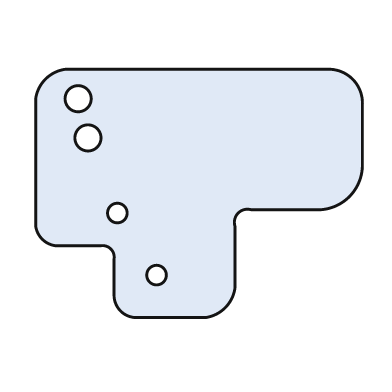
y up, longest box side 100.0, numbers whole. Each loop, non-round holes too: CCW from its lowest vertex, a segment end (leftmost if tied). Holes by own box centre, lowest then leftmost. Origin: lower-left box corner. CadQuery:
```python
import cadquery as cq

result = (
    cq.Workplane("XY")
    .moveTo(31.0, 0.0)
    .lineTo(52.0, 0.0)
    .threePointArc((58.0, 3.0), (61.0, 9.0))
    .lineTo(61.0, 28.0)
    .threePointArc((62.0, 32.0), (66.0, 33.0))
    .lineTo(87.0, 33.0)
    .threePointArc((96.0, 37.0), (100.0, 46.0))
    .lineTo(100.0, 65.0)
    .threePointArc((97.0, 73.0), (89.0, 76.0))
    .lineTo(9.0, 76.0)
    .threePointArc((3.0, 73.0), (0.0, 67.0))
    .lineTo(0.0, 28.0)
    .threePointArc((2.0, 24.0), (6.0, 22.0))
    .lineTo(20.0, 22.0)
    .threePointArc((23.0, 21.0), (24.0, 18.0))
    .lineTo(24.0, 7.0)
    .threePointArc((26.0, 2.0), (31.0, 0.0))
    .close()
    .moveTo(37.0, 13.0)
    .circle(3.0)
    .moveTo(25.0, 32.0)
    .circle(3.0)
    .moveTo(16.0, 55.0)
    .circle(4.0)
    .moveTo(13.0, 67.0)
    .circle(4.0)
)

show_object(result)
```